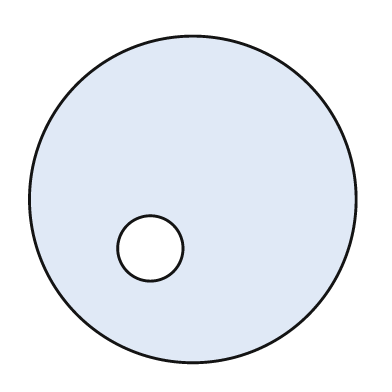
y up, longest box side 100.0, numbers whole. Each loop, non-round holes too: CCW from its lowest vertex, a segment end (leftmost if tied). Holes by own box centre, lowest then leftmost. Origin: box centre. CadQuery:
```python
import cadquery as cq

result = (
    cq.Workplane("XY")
    .moveTo(0.0, 0.0)
    .circle(50.0)
    .moveTo(-13.0, -15.0)
    .circle(10.0)
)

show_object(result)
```